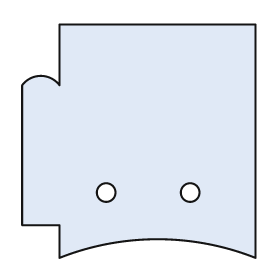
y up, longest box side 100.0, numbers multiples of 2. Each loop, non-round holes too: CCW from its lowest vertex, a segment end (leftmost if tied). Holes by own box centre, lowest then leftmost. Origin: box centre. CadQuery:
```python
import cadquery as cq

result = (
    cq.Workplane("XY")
    .moveTo(-34.0, -50.0)
    .threePointArc((8.0, -42.0), (50.0, -50.0))
    .lineTo(50.0, 50.0)
    .lineTo(-34.0, 50.0)
    .lineTo(-34.0, 24.0)
    .threePointArc((-42.0, 28.0), (-50.0, 24.0))
    .lineTo(-50.0, -36.0)
    .lineTo(-34.0, -36.0)
    .close()
    .moveTo(-14.0, -22.0)
    .circle(4.0)
    .moveTo(22.0, -22.0)
    .circle(4.0)
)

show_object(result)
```